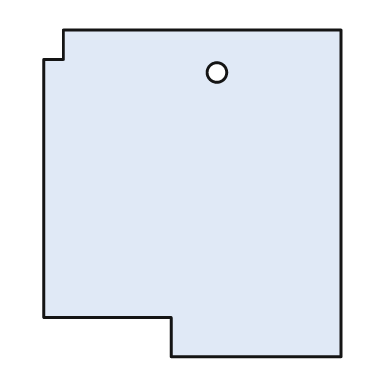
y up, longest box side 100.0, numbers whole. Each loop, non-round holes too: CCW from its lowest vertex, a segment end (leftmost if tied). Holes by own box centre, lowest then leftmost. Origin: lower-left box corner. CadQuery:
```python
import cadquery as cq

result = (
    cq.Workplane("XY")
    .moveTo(39.0, 0.0)
    .lineTo(91.0, 0.0)
    .lineTo(91.0, 100.0)
    .lineTo(6.0, 100.0)
    .lineTo(6.0, 91.0)
    .lineTo(0.0, 91.0)
    .lineTo(0.0, 12.0)
    .lineTo(39.0, 12.0)
    .close()
    .moveTo(53.0, 87.0)
    .circle(3.0)
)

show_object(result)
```